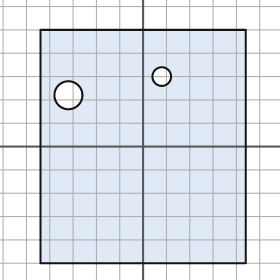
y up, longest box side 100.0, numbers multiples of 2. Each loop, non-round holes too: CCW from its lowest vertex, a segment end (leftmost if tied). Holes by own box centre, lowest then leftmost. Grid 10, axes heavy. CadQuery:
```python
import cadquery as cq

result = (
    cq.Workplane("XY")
    .moveTo(-44.0, -50.0)
    .lineTo(44.0, -50.0)
    .lineTo(44.0, 50.0)
    .lineTo(-44.0, 50.0)
    .close()
    .moveTo(-32.0, 22.0)
    .circle(6.0)
    .moveTo(8.0, 30.0)
    .circle(4.0)
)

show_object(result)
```